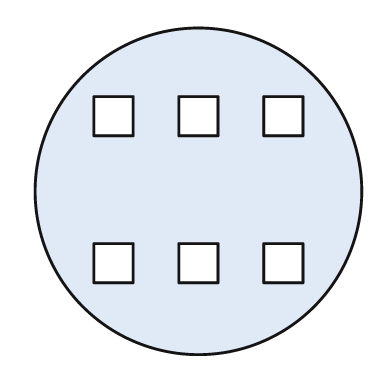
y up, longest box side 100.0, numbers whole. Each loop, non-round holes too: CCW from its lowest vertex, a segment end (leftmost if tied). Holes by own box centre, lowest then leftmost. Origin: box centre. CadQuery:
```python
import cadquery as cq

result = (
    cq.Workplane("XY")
    .moveTo(0.0, 0.0)
    .circle(50.0)
    .moveTo(-32.0, -28.0)
    .lineTo(-20.0, -28.0)
    .lineTo(-20.0, -16.0)
    .lineTo(-32.0, -16.0)
    .close()
    .moveTo(-6.0, -28.0)
    .lineTo(6.0, -28.0)
    .lineTo(6.0, -16.0)
    .lineTo(-6.0, -16.0)
    .close()
    .moveTo(20.0, -28.0)
    .lineTo(32.0, -28.0)
    .lineTo(32.0, -16.0)
    .lineTo(20.0, -16.0)
    .close()
    .moveTo(-32.0, 17.0)
    .lineTo(-20.0, 17.0)
    .lineTo(-20.0, 29.0)
    .lineTo(-32.0, 29.0)
    .close()
    .moveTo(-6.0, 17.0)
    .lineTo(6.0, 17.0)
    .lineTo(6.0, 29.0)
    .lineTo(-6.0, 29.0)
    .close()
    .moveTo(20.0, 17.0)
    .lineTo(32.0, 17.0)
    .lineTo(32.0, 29.0)
    .lineTo(20.0, 29.0)
    .close()
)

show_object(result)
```